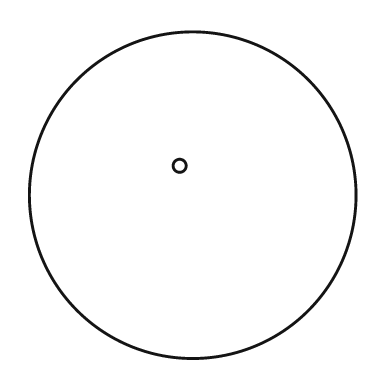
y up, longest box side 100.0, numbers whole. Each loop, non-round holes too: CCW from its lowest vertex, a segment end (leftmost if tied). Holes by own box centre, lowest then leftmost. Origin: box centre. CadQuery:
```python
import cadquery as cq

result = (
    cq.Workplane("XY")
    .moveTo(0.0, 0.0)
    .circle(50.0)
    .moveTo(-4.0, 9.0)
    .circle(2.0)
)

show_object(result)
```